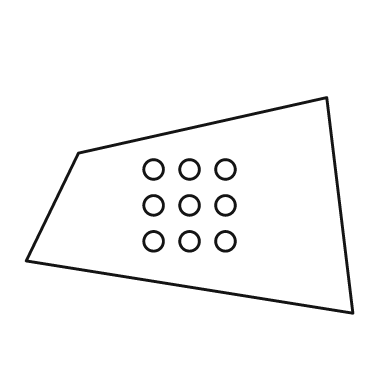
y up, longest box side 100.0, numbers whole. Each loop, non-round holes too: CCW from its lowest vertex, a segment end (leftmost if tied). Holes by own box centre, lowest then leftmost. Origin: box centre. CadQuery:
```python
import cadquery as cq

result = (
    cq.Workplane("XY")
    .moveTo(50.0, -33.0)
    .lineTo(42.0, 33.0)
    .lineTo(-34.0, 16.0)
    .lineTo(-50.0, -17.0)
    .close()
    .moveTo(-11.0, -11.0)
    .circle(3.0)
    .moveTo(0.0, -11.0)
    .circle(3.0)
    .moveTo(11.0, -11.0)
    .circle(3.0)
    .moveTo(-11.0, 0.0)
    .circle(3.0)
    .moveTo(0.0, 0.0)
    .circle(3.0)
    .moveTo(11.0, 0.0)
    .circle(3.0)
    .moveTo(-11.0, 11.0)
    .circle(3.0)
    .moveTo(0.0, 11.0)
    .circle(3.0)
    .moveTo(11.0, 11.0)
    .circle(3.0)
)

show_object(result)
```